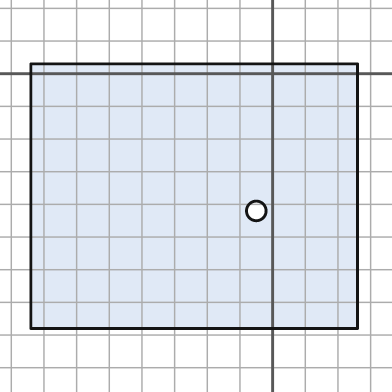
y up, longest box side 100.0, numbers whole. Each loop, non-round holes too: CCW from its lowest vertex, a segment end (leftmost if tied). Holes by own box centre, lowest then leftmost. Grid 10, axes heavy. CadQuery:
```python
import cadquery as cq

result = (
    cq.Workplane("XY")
    .moveTo(-74.0, -78.0)
    .lineTo(26.0, -78.0)
    .lineTo(26.0, 3.0)
    .lineTo(-74.0, 3.0)
    .close()
    .moveTo(-5.0, -42.0)
    .circle(3.0)
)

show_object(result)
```